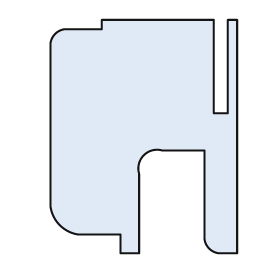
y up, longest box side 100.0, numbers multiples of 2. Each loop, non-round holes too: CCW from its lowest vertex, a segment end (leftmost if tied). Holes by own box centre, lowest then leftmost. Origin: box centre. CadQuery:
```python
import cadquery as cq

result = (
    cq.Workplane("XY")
    .moveTo(-10.0, -50.0)
    .lineTo(-2.0, -50.0)
    .lineTo(-2.0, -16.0)
    .threePointArc((0.0, -8.0), (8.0, -6.0))
    .lineTo(26.0, -6.0)
    .lineTo(26.0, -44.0)
    .threePointArc((28.0, -48.0), (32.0, -50.0))
    .lineTo(40.0, -50.0)
    .lineTo(40.0, 50.0)
    .lineTo(36.0, 50.0)
    .lineTo(36.0, 10.0)
    .lineTo(30.0, 10.0)
    .lineTo(30.0, 50.0)
    .lineTo(-18.0, 50.0)
    .lineTo(-18.0, 46.0)
    .lineTo(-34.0, 46.0)
    .threePointArc((-38.0, 44.0), (-40.0, 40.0))
    .lineTo(-40.0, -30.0)
    .threePointArc((-36.0, -38.0), (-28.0, -42.0))
    .lineTo(-10.0, -42.0)
    .close()
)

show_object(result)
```